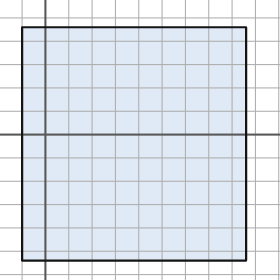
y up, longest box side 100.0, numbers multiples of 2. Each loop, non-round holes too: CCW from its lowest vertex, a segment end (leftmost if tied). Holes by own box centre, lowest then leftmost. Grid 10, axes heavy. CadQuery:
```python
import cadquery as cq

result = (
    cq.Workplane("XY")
    .moveTo(-10.0, -54.0)
    .lineTo(86.0, -54.0)
    .lineTo(86.0, 46.0)
    .lineTo(-10.0, 46.0)
    .close()
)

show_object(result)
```